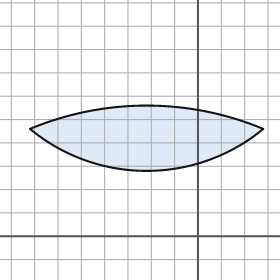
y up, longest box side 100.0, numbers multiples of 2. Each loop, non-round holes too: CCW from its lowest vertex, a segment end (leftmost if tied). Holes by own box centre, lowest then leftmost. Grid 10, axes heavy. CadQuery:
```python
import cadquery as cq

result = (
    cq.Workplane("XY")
    .moveTo(-72.0, 46.0)
    .threePointArc((-22.0, 28.0), (28.0, 46.0))
    .threePointArc((-22.0, 56.0), (-72.0, 46.0))
    .close()
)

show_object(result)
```